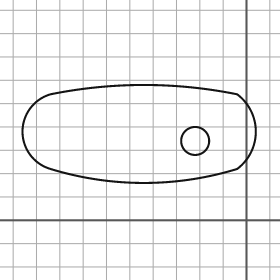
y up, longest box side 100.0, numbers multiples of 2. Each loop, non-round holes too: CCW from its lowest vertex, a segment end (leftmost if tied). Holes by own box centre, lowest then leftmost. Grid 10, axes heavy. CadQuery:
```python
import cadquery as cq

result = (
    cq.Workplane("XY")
    .moveTo(-84.0, 22.0)
    .threePointArc((-44.0, 16.0), (-4.0, 22.0))
    .threePointArc((4.0, 38.0), (-4.0, 54.0))
    .threePointArc((-44.0, 58.0), (-84.0, 54.0))
    .threePointArc((-96.0, 38.0), (-84.0, 22.0))
    .close()
    .moveTo(-22.0, 34.0)
    .circle(6.0)
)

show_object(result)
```